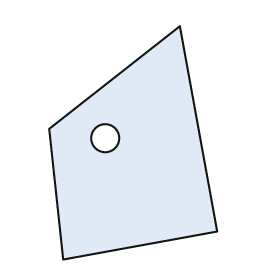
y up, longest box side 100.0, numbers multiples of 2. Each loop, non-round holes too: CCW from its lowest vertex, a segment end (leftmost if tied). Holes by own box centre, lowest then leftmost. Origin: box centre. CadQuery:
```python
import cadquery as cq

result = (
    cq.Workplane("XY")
    .moveTo(-30.0, -50.0)
    .lineTo(36.0, -38.0)
    .lineTo(20.0, 50.0)
    .lineTo(-36.0, 6.0)
    .close()
    .moveTo(-12.0, 2.0)
    .circle(6.0)
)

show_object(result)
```